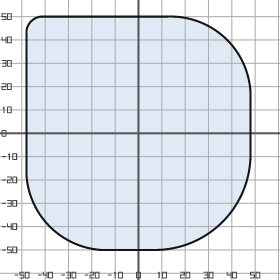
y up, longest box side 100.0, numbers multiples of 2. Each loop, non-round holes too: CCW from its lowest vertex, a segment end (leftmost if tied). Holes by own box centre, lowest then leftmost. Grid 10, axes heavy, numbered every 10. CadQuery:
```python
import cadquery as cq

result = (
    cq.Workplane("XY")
    .moveTo(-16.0, -50.0)
    .lineTo(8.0, -50.0)
    .threePointArc((36.0, -38.0), (48.0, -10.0))
    .lineTo(48.0, 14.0)
    .threePointArc((38.0, 40.0), (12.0, 50.0))
    .lineTo(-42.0, 50.0)
    .threePointArc((-46.0, 48.0), (-48.0, 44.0))
    .lineTo(-48.0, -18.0)
    .threePointArc((-38.0, -40.0), (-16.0, -50.0))
    .close()
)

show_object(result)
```